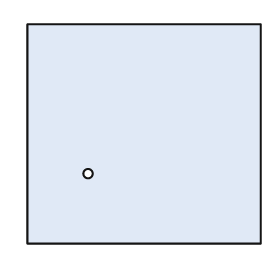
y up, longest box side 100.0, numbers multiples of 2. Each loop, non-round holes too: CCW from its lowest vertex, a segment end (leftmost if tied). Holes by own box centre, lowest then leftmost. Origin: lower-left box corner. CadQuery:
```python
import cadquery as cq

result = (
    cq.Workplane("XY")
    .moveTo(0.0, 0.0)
    .lineTo(100.0, 0.0)
    .lineTo(100.0, 94.0)
    .lineTo(0.0, 94.0)
    .close()
    .moveTo(26.0, 30.0)
    .circle(2.0)
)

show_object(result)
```